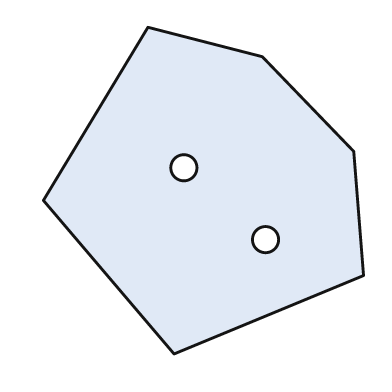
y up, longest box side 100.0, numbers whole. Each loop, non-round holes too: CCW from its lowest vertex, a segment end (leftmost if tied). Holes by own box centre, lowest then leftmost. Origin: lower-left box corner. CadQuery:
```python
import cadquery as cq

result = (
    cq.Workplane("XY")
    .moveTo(40.0, 0.0)
    .lineTo(98.0, 24.0)
    .lineTo(95.0, 62.0)
    .lineTo(67.0, 91.0)
    .lineTo(32.0, 100.0)
    .lineTo(0.0, 47.0)
    .close()
    .moveTo(68.0, 35.0)
    .circle(4.0)
    .moveTo(43.0, 57.0)
    .circle(4.0)
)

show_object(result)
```